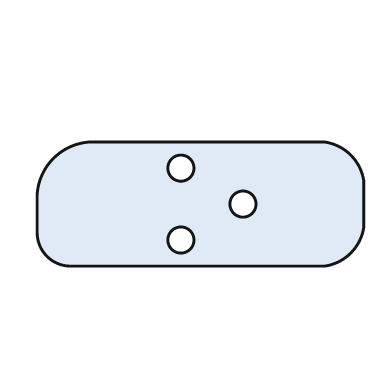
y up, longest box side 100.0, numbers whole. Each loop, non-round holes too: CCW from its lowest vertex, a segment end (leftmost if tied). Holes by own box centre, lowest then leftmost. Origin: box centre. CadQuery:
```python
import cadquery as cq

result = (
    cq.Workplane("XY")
    .moveTo(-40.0, -19.0)
    .lineTo(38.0, -19.0)
    .threePointArc((46.0, -15.0), (50.0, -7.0))
    .lineTo(50.0, 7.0)
    .threePointArc((46.0, 15.0), (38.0, 19.0))
    .lineTo(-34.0, 19.0)
    .threePointArc((-45.0, 14.0), (-50.0, 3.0))
    .lineTo(-50.0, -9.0)
    .threePointArc((-47.0, -16.0), (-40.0, -19.0))
    .close()
    .moveTo(-6.0, -11.0)
    .circle(4.0)
    .moveTo(13.0, 0.0)
    .circle(4.0)
    .moveTo(-6.0, 11.0)
    .circle(4.0)
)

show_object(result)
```